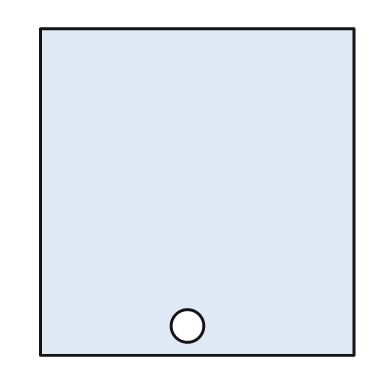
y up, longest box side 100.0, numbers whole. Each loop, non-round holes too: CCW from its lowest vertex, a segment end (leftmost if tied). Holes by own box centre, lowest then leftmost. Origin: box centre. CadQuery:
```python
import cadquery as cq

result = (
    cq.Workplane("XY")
    .moveTo(-48.0, -50.0)
    .lineTo(48.0, -50.0)
    .lineTo(48.0, 50.0)
    .lineTo(-48.0, 50.0)
    .close()
    .moveTo(-3.0, -41.0)
    .circle(5.0)
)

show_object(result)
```